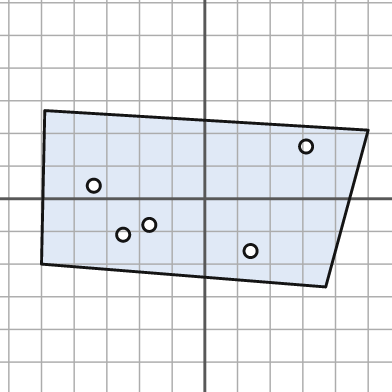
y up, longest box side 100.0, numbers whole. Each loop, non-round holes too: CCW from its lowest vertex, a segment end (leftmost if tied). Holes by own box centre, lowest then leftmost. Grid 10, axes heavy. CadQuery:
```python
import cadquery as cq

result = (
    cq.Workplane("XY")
    .moveTo(37.0, -27.0)
    .lineTo(50.0, 21.0)
    .lineTo(-49.0, 27.0)
    .lineTo(-50.0, -20.0)
    .close()
    .moveTo(14.0, -16.0)
    .circle(2.0)
    .moveTo(-25.0, -11.0)
    .circle(2.0)
    .moveTo(-17.0, -8.0)
    .circle(2.0)
    .moveTo(-34.0, 4.0)
    .circle(2.0)
    .moveTo(31.0, 16.0)
    .circle(2.0)
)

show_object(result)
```